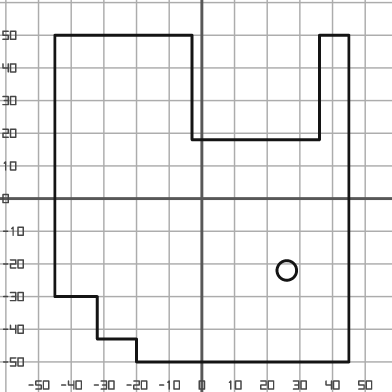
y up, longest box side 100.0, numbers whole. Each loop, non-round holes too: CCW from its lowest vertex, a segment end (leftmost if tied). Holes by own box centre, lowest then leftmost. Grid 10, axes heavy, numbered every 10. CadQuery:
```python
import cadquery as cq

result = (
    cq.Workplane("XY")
    .moveTo(-20.0, -50.0)
    .lineTo(45.0, -50.0)
    .lineTo(45.0, 50.0)
    .lineTo(36.0, 50.0)
    .lineTo(36.0, 18.0)
    .lineTo(-3.0, 18.0)
    .lineTo(-3.0, 50.0)
    .lineTo(-45.0, 50.0)
    .lineTo(-45.0, -30.0)
    .lineTo(-32.0, -30.0)
    .lineTo(-32.0, -43.0)
    .lineTo(-20.0, -43.0)
    .close()
    .moveTo(26.0, -22.0)
    .circle(3.0)
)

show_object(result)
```